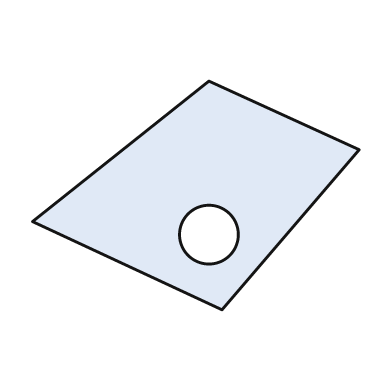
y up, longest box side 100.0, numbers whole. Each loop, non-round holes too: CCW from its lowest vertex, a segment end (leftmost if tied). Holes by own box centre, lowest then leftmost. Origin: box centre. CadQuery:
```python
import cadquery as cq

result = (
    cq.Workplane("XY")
    .moveTo(8.0, -35.0)
    .lineTo(50.0, 14.0)
    .lineTo(4.0, 35.0)
    .lineTo(-50.0, -8.0)
    .close()
    .moveTo(4.0, -12.0)
    .circle(9.0)
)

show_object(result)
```